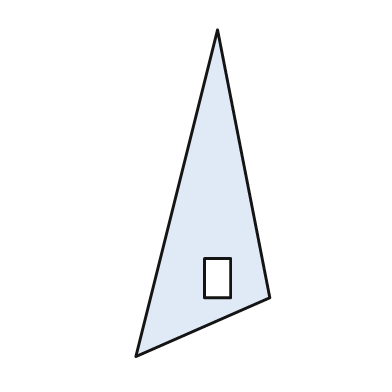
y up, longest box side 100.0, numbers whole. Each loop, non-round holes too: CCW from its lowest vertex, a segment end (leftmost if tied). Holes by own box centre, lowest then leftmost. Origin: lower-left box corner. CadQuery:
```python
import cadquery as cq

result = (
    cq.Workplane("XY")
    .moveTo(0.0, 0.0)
    .lineTo(41.0, 18.0)
    .lineTo(25.0, 100.0)
    .close()
    .moveTo(21.0, 18.0)
    .lineTo(29.0, 18.0)
    .lineTo(29.0, 30.0)
    .lineTo(21.0, 30.0)
    .close()
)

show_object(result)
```